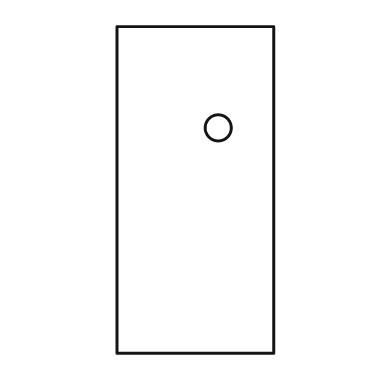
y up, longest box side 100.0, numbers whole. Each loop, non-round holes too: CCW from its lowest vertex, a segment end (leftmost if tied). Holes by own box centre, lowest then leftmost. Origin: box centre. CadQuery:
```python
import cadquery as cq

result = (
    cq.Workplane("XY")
    .moveTo(-24.0, -50.0)
    .lineTo(24.0, -50.0)
    .lineTo(24.0, 50.0)
    .lineTo(-24.0, 50.0)
    .close()
    .moveTo(7.0, 19.0)
    .circle(4.0)
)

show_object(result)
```